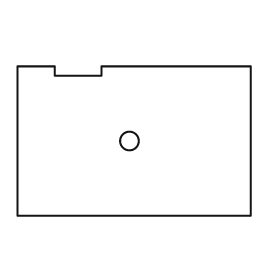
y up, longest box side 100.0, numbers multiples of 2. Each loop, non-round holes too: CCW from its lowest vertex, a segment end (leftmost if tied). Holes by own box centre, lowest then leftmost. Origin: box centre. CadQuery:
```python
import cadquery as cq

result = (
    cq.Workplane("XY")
    .moveTo(-50.0, -32.0)
    .lineTo(50.0, -32.0)
    .lineTo(50.0, 32.0)
    .lineTo(-14.0, 32.0)
    .lineTo(-14.0, 28.0)
    .lineTo(-34.0, 28.0)
    .lineTo(-34.0, 32.0)
    .lineTo(-50.0, 32.0)
    .close()
    .moveTo(-2.0, 0.0)
    .circle(4.0)
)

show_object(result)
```